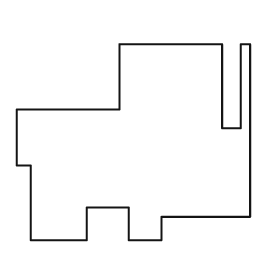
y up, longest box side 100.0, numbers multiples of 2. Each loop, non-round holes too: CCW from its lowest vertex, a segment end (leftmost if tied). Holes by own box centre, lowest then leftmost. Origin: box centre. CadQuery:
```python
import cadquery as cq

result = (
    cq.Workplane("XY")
    .moveTo(-44.0, -42.0)
    .lineTo(-20.0, -42.0)
    .lineTo(-20.0, -28.0)
    .lineTo(-2.0, -28.0)
    .lineTo(-2.0, -42.0)
    .lineTo(12.0, -42.0)
    .lineTo(12.0, -32.0)
    .lineTo(50.0, -32.0)
    .lineTo(50.0, 42.0)
    .lineTo(46.0, 42.0)
    .lineTo(46.0, 6.0)
    .lineTo(38.0, 6.0)
    .lineTo(38.0, 42.0)
    .lineTo(-6.0, 42.0)
    .lineTo(-6.0, 14.0)
    .lineTo(-50.0, 14.0)
    .lineTo(-50.0, -10.0)
    .lineTo(-44.0, -10.0)
    .close()
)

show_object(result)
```